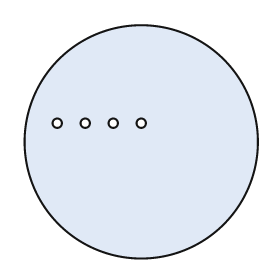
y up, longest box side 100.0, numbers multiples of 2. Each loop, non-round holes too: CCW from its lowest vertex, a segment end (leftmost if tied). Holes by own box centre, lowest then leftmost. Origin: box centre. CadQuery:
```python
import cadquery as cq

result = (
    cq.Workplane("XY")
    .moveTo(0.0, 0.0)
    .circle(50.0)
    .moveTo(-36.0, 8.0)
    .circle(2.0)
    .moveTo(-24.0, 8.0)
    .circle(2.0)
    .moveTo(-12.0, 8.0)
    .circle(2.0)
    .moveTo(0.0, 8.0)
    .circle(2.0)
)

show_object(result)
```